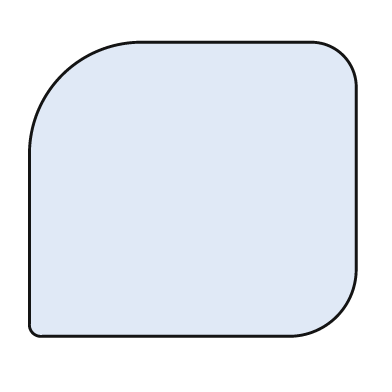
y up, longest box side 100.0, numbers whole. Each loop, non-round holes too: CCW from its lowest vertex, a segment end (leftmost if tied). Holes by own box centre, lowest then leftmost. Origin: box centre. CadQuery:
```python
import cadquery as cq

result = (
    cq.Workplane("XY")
    .moveTo(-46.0, -45.0)
    .lineTo(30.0, -45.0)
    .threePointArc((44.0, -39.0), (50.0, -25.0))
    .lineTo(50.0, 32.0)
    .threePointArc((46.0, 41.0), (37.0, 45.0))
    .lineTo(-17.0, 45.0)
    .threePointArc((-40.0, 35.0), (-50.0, 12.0))
    .lineTo(-50.0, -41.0)
    .threePointArc((-49.0, -44.0), (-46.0, -45.0))
    .close()
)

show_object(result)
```